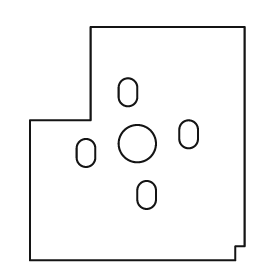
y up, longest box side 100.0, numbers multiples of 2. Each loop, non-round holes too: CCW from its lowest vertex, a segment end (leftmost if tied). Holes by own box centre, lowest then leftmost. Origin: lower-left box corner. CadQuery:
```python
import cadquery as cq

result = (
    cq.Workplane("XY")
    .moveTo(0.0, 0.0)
    .lineTo(88.0, 0.0)
    .lineTo(88.0, 6.0)
    .lineTo(92.0, 6.0)
    .lineTo(92.0, 100.0)
    .lineTo(26.0, 100.0)
    .lineTo(26.0, 60.0)
    .lineTo(0.0, 60.0)
    .close()
    .moveTo(46.0, 26.0)
    .threePointArc((50.0, 22.0), (54.0, 26.0))
    .lineTo(54.0, 30.0)
    .threePointArc((50.0, 34.0), (46.0, 30.0))
    .close()
    .moveTo(20.0, 44.0)
    .threePointArc((24.0, 40.0), (28.0, 44.0))
    .lineTo(28.0, 48.0)
    .threePointArc((24.0, 52.0), (20.0, 48.0))
    .close()
    .moveTo(46.0, 50.0)
    .circle(8.0)
    .moveTo(64.0, 52.0)
    .threePointArc((68.0, 48.0), (72.0, 52.0))
    .lineTo(72.0, 56.0)
    .threePointArc((68.0, 60.0), (64.0, 56.0))
    .close()
    .moveTo(38.0, 70.0)
    .threePointArc((42.0, 66.0), (46.0, 70.0))
    .lineTo(46.0, 74.0)
    .threePointArc((42.0, 78.0), (38.0, 74.0))
    .close()
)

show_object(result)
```